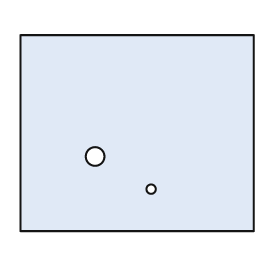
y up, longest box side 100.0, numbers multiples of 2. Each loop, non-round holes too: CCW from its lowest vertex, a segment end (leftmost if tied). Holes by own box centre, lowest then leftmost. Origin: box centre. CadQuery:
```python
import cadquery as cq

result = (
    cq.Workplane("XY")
    .moveTo(-50.0, -42.0)
    .lineTo(50.0, -42.0)
    .lineTo(50.0, 42.0)
    .lineTo(-50.0, 42.0)
    .close()
    .moveTo(6.0, -24.0)
    .circle(2.0)
    .moveTo(-18.0, -10.0)
    .circle(4.0)
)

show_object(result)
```